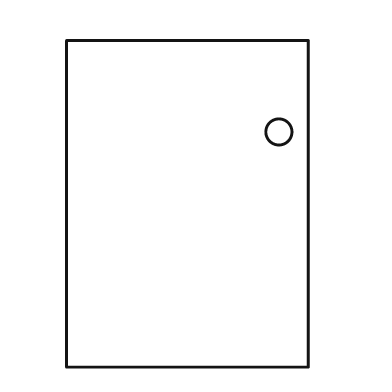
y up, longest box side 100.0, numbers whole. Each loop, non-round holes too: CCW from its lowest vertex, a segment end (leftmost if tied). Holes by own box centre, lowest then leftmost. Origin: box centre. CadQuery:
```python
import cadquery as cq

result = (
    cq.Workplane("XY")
    .moveTo(-37.0, -50.0)
    .lineTo(37.0, -50.0)
    .lineTo(37.0, 50.0)
    .lineTo(-37.0, 50.0)
    .close()
    .moveTo(28.0, 22.0)
    .circle(4.0)
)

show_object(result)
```